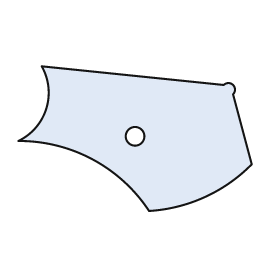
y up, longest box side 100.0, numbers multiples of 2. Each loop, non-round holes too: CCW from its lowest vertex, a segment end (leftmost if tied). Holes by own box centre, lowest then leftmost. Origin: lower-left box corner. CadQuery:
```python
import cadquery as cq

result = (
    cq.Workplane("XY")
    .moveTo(56.0, 0.0)
    .threePointArc((80.0, 6.0), (100.0, 20.0))
    .lineTo(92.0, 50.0)
    .threePointArc((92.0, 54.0), (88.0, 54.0))
    .lineTo(10.0, 62.0)
    .threePointArc((12.0, 44.0), (0.0, 30.0))
    .threePointArc((32.0, 22.0), (56.0, 0.0))
    .close()
    .moveTo(50.0, 32.0)
    .circle(4.0)
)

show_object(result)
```